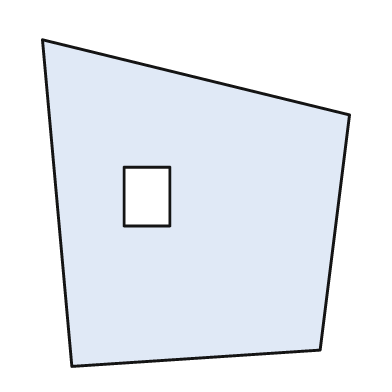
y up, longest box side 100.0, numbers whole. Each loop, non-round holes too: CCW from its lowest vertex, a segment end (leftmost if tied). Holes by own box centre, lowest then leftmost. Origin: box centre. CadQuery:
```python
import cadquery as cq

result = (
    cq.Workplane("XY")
    .moveTo(-38.0, -50.0)
    .lineTo(38.0, -45.0)
    .lineTo(47.0, 27.0)
    .lineTo(-47.0, 50.0)
    .close()
    .moveTo(-22.0, -7.0)
    .lineTo(-8.0, -7.0)
    .lineTo(-8.0, 11.0)
    .lineTo(-22.0, 11.0)
    .close()
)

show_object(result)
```